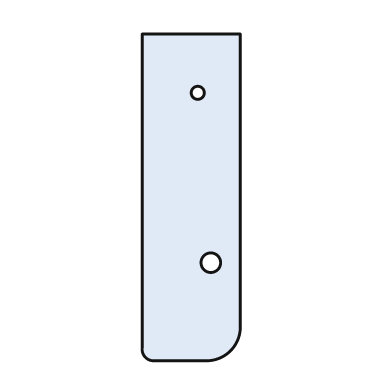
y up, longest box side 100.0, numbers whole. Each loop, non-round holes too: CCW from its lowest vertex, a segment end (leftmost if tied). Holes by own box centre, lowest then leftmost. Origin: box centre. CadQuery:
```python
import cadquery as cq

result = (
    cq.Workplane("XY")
    .moveTo(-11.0, -50.0)
    .lineTo(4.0, -50.0)
    .threePointArc((12.0, -47.0), (15.0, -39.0))
    .lineTo(15.0, 50.0)
    .lineTo(-15.0, 50.0)
    .lineTo(-15.0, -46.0)
    .threePointArc((-14.0, -49.0), (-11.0, -50.0))
    .close()
    .moveTo(6.0, -20.0)
    .circle(3.0)
    .moveTo(2.0, 32.0)
    .circle(2.0)
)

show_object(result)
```